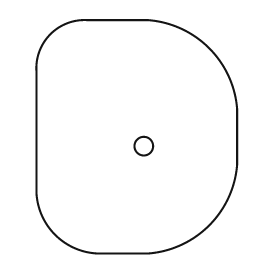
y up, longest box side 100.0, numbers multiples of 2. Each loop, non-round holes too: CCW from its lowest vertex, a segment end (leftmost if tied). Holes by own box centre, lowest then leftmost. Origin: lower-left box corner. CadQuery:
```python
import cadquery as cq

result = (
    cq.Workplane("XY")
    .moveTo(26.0, 0.0)
    .lineTo(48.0, 0.0)
    .threePointArc((74.0, 12.0), (86.0, 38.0))
    .lineTo(86.0, 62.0)
    .threePointArc((74.0, 88.0), (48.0, 100.0))
    .lineTo(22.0, 100.0)
    .threePointArc((6.0, 94.0), (0.0, 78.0))
    .lineTo(0.0, 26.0)
    .threePointArc((8.0, 8.0), (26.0, 0.0))
    .close()
    .moveTo(46.0, 46.0)
    .circle(4.0)
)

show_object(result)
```